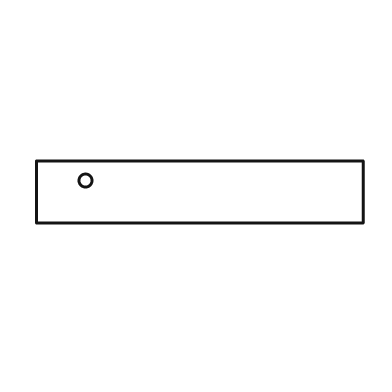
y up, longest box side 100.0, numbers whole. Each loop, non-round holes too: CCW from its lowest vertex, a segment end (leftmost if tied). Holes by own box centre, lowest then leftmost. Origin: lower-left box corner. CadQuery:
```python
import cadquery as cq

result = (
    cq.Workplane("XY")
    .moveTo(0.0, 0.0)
    .lineTo(100.0, 0.0)
    .lineTo(100.0, 19.0)
    .lineTo(0.0, 19.0)
    .close()
    .moveTo(15.0, 13.0)
    .circle(2.0)
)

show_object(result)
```